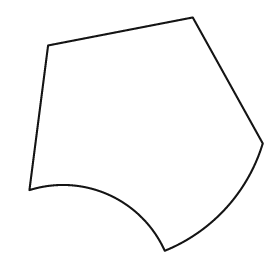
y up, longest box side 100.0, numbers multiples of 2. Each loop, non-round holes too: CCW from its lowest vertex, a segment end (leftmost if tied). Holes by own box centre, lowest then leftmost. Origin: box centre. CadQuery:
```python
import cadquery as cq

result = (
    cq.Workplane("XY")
    .moveTo(8.0, -50.0)
    .threePointArc((34.0, -32.0), (50.0, -4.0))
    .lineTo(20.0, 50.0)
    .lineTo(-42.0, 38.0)
    .lineTo(-50.0, -24.0)
    .threePointArc((-16.0, -26.0), (8.0, -50.0))
    .close()
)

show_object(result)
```